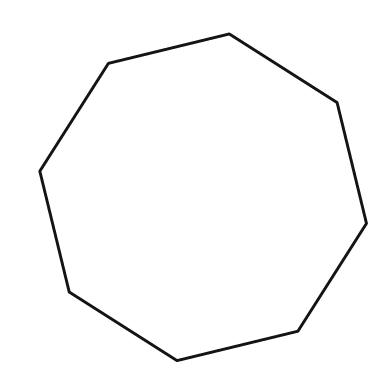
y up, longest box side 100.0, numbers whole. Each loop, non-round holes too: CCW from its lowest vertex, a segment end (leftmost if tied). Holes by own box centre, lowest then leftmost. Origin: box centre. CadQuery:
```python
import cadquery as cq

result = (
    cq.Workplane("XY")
    .moveTo(-8.0, -50.0)
    .lineTo(29.0, -41.0)
    .lineTo(50.0, -8.0)
    .lineTo(41.0, 29.0)
    .lineTo(8.0, 50.0)
    .lineTo(-29.0, 41.0)
    .lineTo(-50.0, 8.0)
    .lineTo(-41.0, -29.0)
    .close()
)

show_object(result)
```